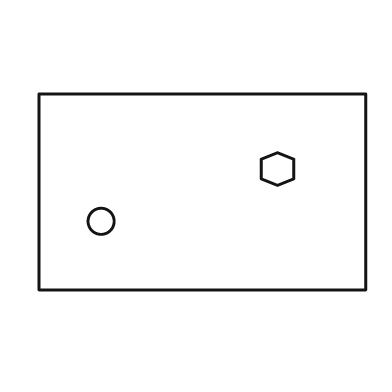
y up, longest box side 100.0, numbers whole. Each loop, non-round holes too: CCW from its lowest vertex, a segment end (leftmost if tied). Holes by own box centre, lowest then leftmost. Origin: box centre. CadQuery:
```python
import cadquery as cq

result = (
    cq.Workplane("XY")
    .moveTo(-50.0, -30.0)
    .lineTo(50.0, -30.0)
    .lineTo(50.0, 30.0)
    .lineTo(-50.0, 30.0)
    .close()
    .moveTo(-31.0, -9.0)
    .circle(4.0)
    .moveTo(23.0, 2.0)
    .lineTo(28.0, 4.0)
    .lineTo(28.0, 10.0)
    .lineTo(23.0, 12.0)
    .lineTo(18.0, 10.0)
    .lineTo(18.0, 4.0)
    .close()
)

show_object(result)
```